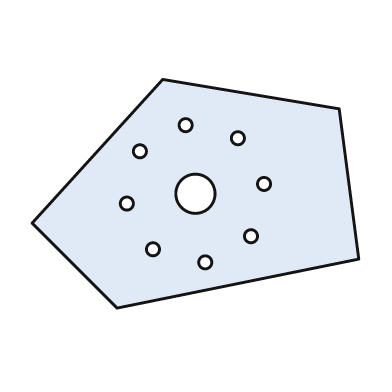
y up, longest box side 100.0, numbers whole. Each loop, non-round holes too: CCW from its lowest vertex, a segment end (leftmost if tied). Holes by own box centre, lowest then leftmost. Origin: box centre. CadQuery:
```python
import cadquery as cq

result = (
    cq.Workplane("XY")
    .moveTo(-24.0, -35.0)
    .lineTo(50.0, -20.0)
    .lineTo(44.0, 26.0)
    .lineTo(-10.0, 35.0)
    .lineTo(-50.0, -9.0)
    .close()
    .moveTo(3.0, -21.0)
    .circle(2.0)
    .moveTo(-13.0, -17.0)
    .circle(2.0)
    .moveTo(17.0, -13.0)
    .circle(2.0)
    .moveTo(-21.0, -3.0)
    .circle(2.0)
    .moveTo(0.0, 0.0)
    .circle(6.0)
    .moveTo(21.0, 3.0)
    .circle(2.0)
    .moveTo(-17.0, 13.0)
    .circle(2.0)
    .moveTo(13.0, 17.0)
    .circle(2.0)
    .moveTo(-3.0, 21.0)
    .circle(2.0)
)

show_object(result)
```